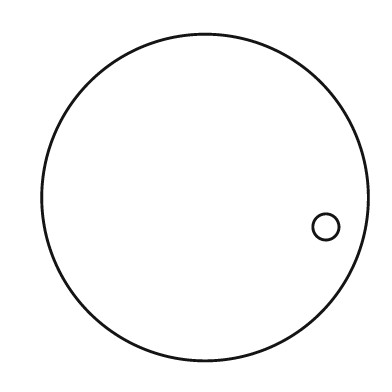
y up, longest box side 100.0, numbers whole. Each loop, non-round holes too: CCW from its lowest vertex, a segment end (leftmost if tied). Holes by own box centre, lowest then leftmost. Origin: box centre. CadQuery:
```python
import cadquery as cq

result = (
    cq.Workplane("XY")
    .moveTo(0.0, 0.0)
    .circle(50.0)
    .moveTo(37.0, -9.0)
    .circle(4.0)
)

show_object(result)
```